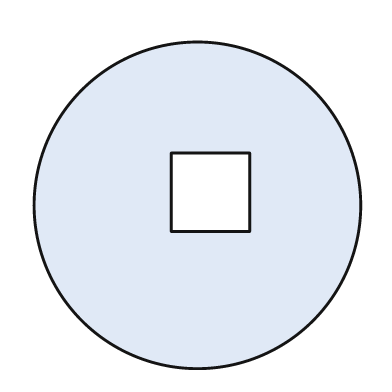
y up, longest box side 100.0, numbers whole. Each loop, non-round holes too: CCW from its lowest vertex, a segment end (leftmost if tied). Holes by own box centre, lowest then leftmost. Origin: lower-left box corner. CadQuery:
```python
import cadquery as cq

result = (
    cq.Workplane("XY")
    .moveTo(50.0, 50.0)
    .circle(50.0)
    .moveTo(42.0, 42.0)
    .lineTo(66.0, 42.0)
    .lineTo(66.0, 66.0)
    .lineTo(42.0, 66.0)
    .close()
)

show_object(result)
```